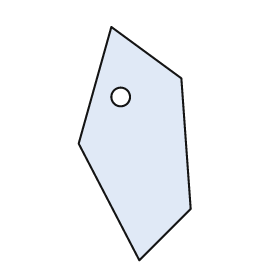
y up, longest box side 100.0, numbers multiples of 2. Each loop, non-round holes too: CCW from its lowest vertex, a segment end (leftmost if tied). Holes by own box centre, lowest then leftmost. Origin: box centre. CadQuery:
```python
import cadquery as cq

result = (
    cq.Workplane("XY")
    .moveTo(2.0, -50.0)
    .lineTo(24.0, -28.0)
    .lineTo(20.0, 28.0)
    .lineTo(-10.0, 50.0)
    .lineTo(-24.0, 0.0)
    .close()
    .moveTo(-6.0, 20.0)
    .circle(4.0)
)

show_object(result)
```